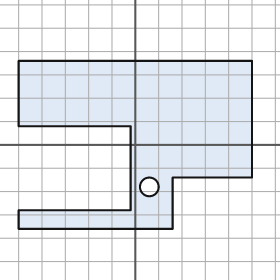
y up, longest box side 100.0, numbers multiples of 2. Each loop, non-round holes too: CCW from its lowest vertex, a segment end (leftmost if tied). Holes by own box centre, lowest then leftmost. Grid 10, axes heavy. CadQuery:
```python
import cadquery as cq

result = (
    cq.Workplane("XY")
    .moveTo(-50.0, -36.0)
    .lineTo(16.0, -36.0)
    .lineTo(16.0, -14.0)
    .lineTo(50.0, -14.0)
    .lineTo(50.0, 36.0)
    .lineTo(-50.0, 36.0)
    .lineTo(-50.0, 8.0)
    .lineTo(-2.0, 8.0)
    .lineTo(-2.0, -28.0)
    .lineTo(-50.0, -28.0)
    .close()
    .moveTo(6.0, -18.0)
    .circle(4.0)
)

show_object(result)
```